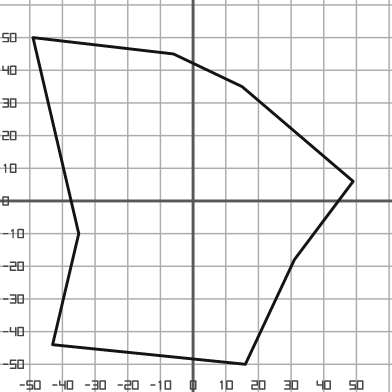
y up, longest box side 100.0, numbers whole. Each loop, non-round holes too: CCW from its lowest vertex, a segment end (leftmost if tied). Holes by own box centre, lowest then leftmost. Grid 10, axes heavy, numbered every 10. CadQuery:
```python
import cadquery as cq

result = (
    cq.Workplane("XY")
    .moveTo(16.0, -50.0)
    .lineTo(31.0, -18.0)
    .lineTo(49.0, 6.0)
    .lineTo(15.0, 35.0)
    .lineTo(-6.0, 45.0)
    .lineTo(-49.0, 50.0)
    .lineTo(-35.0, -10.0)
    .lineTo(-43.0, -44.0)
    .close()
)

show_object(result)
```